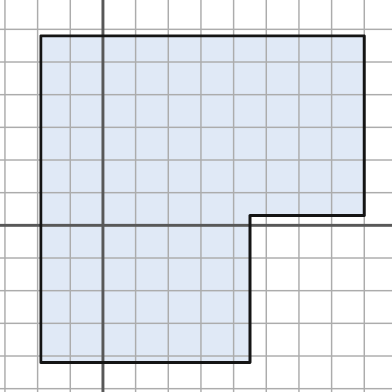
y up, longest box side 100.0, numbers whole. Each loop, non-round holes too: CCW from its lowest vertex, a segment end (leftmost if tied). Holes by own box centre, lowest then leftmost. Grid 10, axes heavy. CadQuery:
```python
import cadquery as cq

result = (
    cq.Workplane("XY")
    .moveTo(-19.0, -42.0)
    .lineTo(45.0, -42.0)
    .lineTo(45.0, 3.0)
    .lineTo(80.0, 3.0)
    .lineTo(80.0, 58.0)
    .lineTo(-19.0, 58.0)
    .close()
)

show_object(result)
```